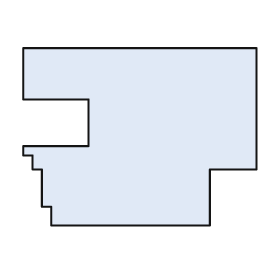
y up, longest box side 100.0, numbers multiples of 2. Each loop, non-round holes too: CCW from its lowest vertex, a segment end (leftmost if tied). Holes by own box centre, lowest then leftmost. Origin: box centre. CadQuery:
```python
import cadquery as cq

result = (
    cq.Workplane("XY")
    .moveTo(-38.0, -38.0)
    .lineTo(30.0, -38.0)
    .lineTo(30.0, -14.0)
    .lineTo(50.0, -14.0)
    .lineTo(50.0, 38.0)
    .lineTo(-50.0, 38.0)
    .lineTo(-50.0, 16.0)
    .lineTo(-22.0, 16.0)
    .lineTo(-22.0, -4.0)
    .lineTo(-50.0, -4.0)
    .lineTo(-50.0, -8.0)
    .lineTo(-46.0, -8.0)
    .lineTo(-46.0, -14.0)
    .lineTo(-42.0, -14.0)
    .lineTo(-42.0, -30.0)
    .lineTo(-38.0, -30.0)
    .close()
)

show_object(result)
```